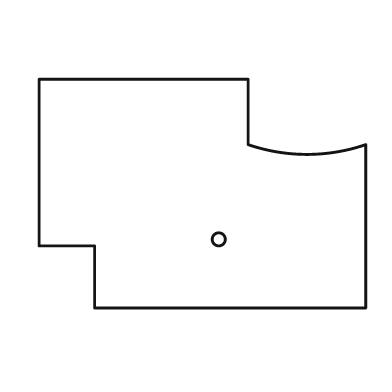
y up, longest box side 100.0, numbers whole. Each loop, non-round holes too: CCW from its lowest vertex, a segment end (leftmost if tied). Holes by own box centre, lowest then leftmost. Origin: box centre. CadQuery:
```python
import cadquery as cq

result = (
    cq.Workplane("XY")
    .moveTo(-33.0, -35.0)
    .lineTo(50.0, -35.0)
    .lineTo(50.0, 15.0)
    .threePointArc((32.0, 12.0), (14.0, 15.0))
    .lineTo(14.0, 35.0)
    .lineTo(-50.0, 35.0)
    .lineTo(-50.0, -16.0)
    .lineTo(-33.0, -16.0)
    .close()
    .moveTo(5.0, -14.0)
    .circle(2.0)
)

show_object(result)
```